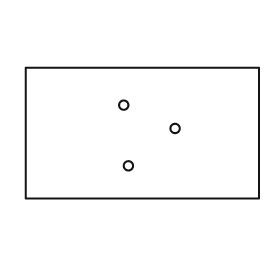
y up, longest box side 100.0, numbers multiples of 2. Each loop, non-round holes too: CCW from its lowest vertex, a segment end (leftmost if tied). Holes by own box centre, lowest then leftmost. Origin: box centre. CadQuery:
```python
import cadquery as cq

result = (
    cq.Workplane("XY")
    .moveTo(-50.0, -28.0)
    .lineTo(50.0, -28.0)
    .lineTo(50.0, 28.0)
    .lineTo(-50.0, 28.0)
    .close()
    .moveTo(-6.0, -14.0)
    .circle(2.0)
    .moveTo(14.0, 2.0)
    .circle(2.0)
    .moveTo(-8.0, 12.0)
    .circle(2.0)
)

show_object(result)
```